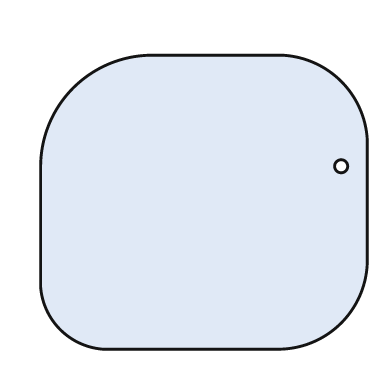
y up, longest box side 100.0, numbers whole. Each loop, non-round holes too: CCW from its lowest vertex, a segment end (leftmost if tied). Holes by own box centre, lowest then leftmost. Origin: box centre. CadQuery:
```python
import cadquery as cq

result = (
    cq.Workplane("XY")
    .moveTo(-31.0, -45.0)
    .lineTo(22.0, -45.0)
    .threePointArc((42.0, -37.0), (50.0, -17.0))
    .lineTo(50.0, 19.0)
    .threePointArc((42.0, 37.0), (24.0, 45.0))
    .lineTo(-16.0, 45.0)
    .threePointArc((-40.0, 35.0), (-50.0, 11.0))
    .lineTo(-50.0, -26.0)
    .threePointArc((-44.0, -39.0), (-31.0, -45.0))
    .close()
    .moveTo(42.0, 11.0)
    .circle(2.0)
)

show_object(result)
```